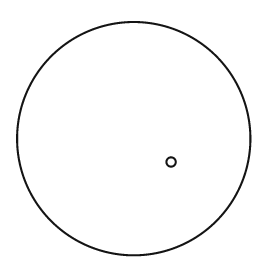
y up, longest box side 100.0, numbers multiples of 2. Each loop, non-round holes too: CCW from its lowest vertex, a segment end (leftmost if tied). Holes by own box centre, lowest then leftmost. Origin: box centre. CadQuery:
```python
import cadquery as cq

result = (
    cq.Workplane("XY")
    .moveTo(0.0, 0.0)
    .circle(50.0)
    .moveTo(16.0, -10.0)
    .circle(2.0)
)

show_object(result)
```